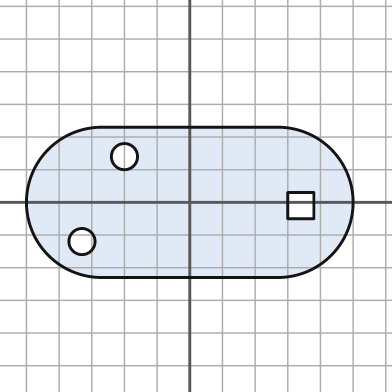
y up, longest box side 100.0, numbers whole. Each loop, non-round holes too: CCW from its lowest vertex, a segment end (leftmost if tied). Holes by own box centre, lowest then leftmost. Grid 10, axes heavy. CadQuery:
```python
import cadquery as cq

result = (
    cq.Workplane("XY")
    .moveTo(-27.0, -23.0)
    .lineTo(27.0, -23.0)
    .threePointArc((50.0, 0.0), (27.0, 23.0))
    .lineTo(-27.0, 23.0)
    .threePointArc((-50.0, 0.0), (-27.0, -23.0))
    .close()
    .moveTo(-33.0, -12.0)
    .circle(4.0)
    .moveTo(30.0, -5.0)
    .lineTo(38.0, -5.0)
    .lineTo(38.0, 3.0)
    .lineTo(30.0, 3.0)
    .close()
    .moveTo(-20.0, 14.0)
    .circle(4.0)
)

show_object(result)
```